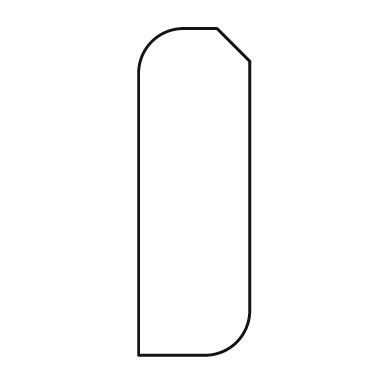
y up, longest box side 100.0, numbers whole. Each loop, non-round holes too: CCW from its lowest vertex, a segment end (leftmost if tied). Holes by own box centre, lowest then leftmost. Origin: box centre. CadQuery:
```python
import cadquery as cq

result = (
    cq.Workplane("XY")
    .moveTo(-17.0, -50.0)
    .lineTo(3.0, -50.0)
    .threePointArc((13.0, -46.0), (17.0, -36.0))
    .lineTo(17.0, 40.0)
    .lineTo(7.0, 50.0)
    .lineTo(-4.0, 50.0)
    .threePointArc((-13.0, 46.0), (-17.0, 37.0))
    .close()
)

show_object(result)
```